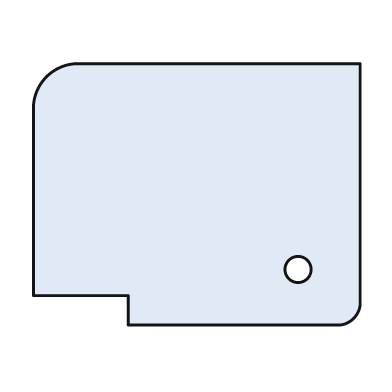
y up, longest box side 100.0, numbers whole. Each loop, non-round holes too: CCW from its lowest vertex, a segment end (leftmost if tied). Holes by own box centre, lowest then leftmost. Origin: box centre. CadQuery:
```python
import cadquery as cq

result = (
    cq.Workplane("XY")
    .moveTo(-21.0, -40.0)
    .lineTo(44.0, -40.0)
    .threePointArc((48.0, -38.0), (50.0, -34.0))
    .lineTo(50.0, 40.0)
    .lineTo(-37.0, 40.0)
    .threePointArc((-46.0, 36.0), (-50.0, 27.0))
    .lineTo(-50.0, -31.0)
    .lineTo(-21.0, -31.0)
    .close()
    .moveTo(31.0, -23.0)
    .circle(4.0)
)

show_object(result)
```